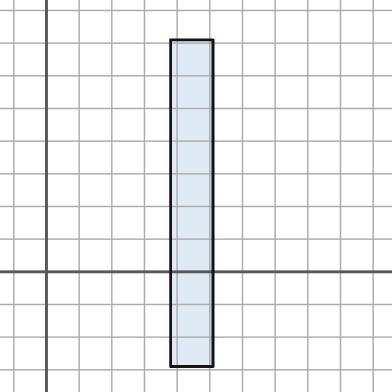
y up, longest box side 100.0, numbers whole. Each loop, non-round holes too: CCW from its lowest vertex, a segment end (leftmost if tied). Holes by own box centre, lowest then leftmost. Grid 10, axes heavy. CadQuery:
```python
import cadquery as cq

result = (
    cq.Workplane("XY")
    .moveTo(38.0, -29.0)
    .lineTo(51.0, -29.0)
    .lineTo(51.0, 71.0)
    .lineTo(38.0, 71.0)
    .close()
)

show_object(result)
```